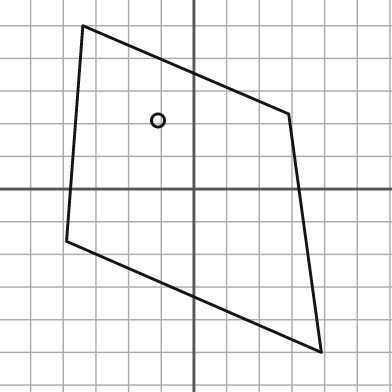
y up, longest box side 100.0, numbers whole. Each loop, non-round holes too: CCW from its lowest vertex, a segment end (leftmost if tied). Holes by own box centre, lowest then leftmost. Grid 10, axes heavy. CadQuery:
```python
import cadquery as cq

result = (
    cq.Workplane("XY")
    .moveTo(39.0, -50.0)
    .lineTo(29.0, 23.0)
    .lineTo(-34.0, 50.0)
    .lineTo(-39.0, -16.0)
    .close()
    .moveTo(-11.0, 21.0)
    .circle(2.0)
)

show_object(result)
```